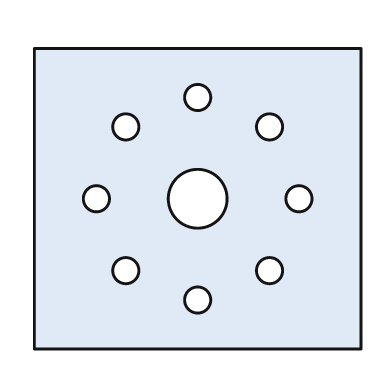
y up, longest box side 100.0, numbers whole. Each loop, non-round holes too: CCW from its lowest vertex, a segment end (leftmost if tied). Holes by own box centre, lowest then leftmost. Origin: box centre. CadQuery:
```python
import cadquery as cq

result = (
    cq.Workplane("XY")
    .moveTo(-50.0, -46.0)
    .lineTo(50.0, -46.0)
    .lineTo(50.0, 46.0)
    .lineTo(-50.0, 46.0)
    .close()
    .moveTo(0.0, -31.0)
    .circle(4.0)
    .moveTo(-22.0, -22.0)
    .circle(4.0)
    .moveTo(22.0, -22.0)
    .circle(4.0)
    .moveTo(-31.0, 0.0)
    .circle(4.0)
    .moveTo(0.0, 0.0)
    .circle(9.0)
    .moveTo(31.0, 0.0)
    .circle(4.0)
    .moveTo(-22.0, 22.0)
    .circle(4.0)
    .moveTo(22.0, 22.0)
    .circle(4.0)
    .moveTo(0.0, 31.0)
    .circle(4.0)
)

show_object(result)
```